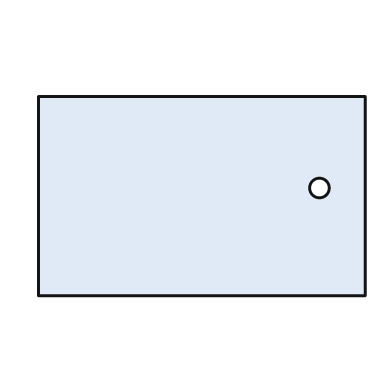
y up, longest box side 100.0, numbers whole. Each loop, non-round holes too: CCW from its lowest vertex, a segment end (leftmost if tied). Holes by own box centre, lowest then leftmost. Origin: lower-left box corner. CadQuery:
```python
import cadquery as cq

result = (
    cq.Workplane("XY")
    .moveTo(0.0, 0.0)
    .lineTo(100.0, 0.0)
    .lineTo(100.0, 61.0)
    .lineTo(0.0, 61.0)
    .close()
    .moveTo(86.0, 33.0)
    .circle(3.0)
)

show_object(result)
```